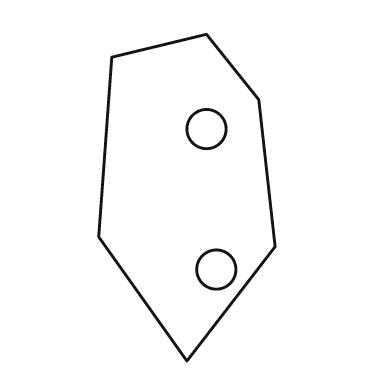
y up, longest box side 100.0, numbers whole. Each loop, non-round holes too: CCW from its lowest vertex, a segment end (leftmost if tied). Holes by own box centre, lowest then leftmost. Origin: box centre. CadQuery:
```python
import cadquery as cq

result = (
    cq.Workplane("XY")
    .moveTo(0.0, -50.0)
    .lineTo(27.0, -15.0)
    .lineTo(22.0, 30.0)
    .lineTo(6.0, 50.0)
    .lineTo(-23.0, 43.0)
    .lineTo(-27.0, -12.0)
    .close()
    .moveTo(9.0, -22.0)
    .circle(6.0)
    .moveTo(6.0, 21.0)
    .circle(6.0)
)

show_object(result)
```